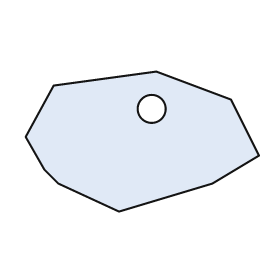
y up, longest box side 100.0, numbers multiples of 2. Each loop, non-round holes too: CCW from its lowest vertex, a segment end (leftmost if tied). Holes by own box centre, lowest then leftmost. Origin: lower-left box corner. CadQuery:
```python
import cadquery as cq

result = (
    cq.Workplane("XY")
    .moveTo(40.0, 0.0)
    .lineTo(80.0, 12.0)
    .lineTo(100.0, 24.0)
    .lineTo(88.0, 48.0)
    .lineTo(56.0, 60.0)
    .lineTo(12.0, 54.0)
    .lineTo(0.0, 32.0)
    .lineTo(8.0, 18.0)
    .lineTo(14.0, 12.0)
    .close()
    .moveTo(54.0, 44.0)
    .circle(6.0)
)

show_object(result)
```